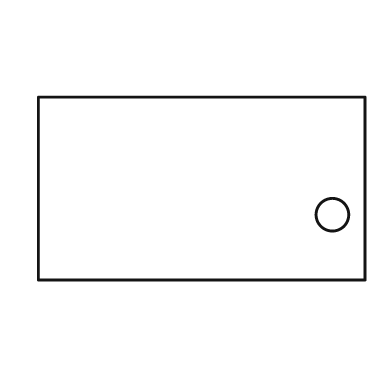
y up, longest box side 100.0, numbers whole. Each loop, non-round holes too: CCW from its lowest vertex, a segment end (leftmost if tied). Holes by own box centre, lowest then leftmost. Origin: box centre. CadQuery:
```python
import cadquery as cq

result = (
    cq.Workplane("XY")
    .moveTo(-50.0, -28.0)
    .lineTo(50.0, -28.0)
    .lineTo(50.0, 28.0)
    .lineTo(-50.0, 28.0)
    .close()
    .moveTo(40.0, -8.0)
    .circle(5.0)
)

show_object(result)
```